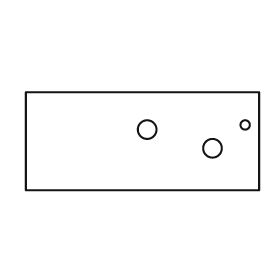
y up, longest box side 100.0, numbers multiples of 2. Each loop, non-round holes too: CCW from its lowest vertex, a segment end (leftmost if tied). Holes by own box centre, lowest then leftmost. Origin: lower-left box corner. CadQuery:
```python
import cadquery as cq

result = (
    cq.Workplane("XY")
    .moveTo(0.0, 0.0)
    .lineTo(100.0, 0.0)
    .lineTo(100.0, 42.0)
    .lineTo(0.0, 42.0)
    .close()
    .moveTo(80.0, 18.0)
    .circle(4.0)
    .moveTo(52.0, 26.0)
    .circle(4.0)
    .moveTo(94.0, 28.0)
    .circle(2.0)
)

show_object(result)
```